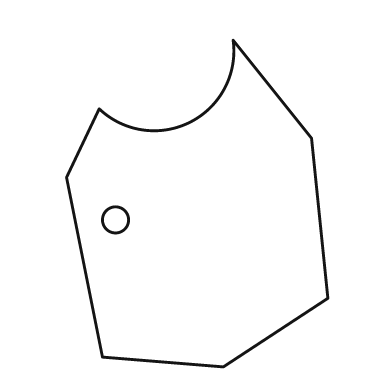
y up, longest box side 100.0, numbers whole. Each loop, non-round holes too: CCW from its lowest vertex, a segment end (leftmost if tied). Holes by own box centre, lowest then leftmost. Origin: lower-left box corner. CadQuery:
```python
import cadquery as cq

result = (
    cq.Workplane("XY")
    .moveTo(48.0, 0.0)
    .lineTo(80.0, 21.0)
    .lineTo(75.0, 70.0)
    .lineTo(51.0, 100.0)
    .threePointArc((38.0, 75.0), (10.0, 79.0))
    .lineTo(0.0, 58.0)
    .lineTo(11.0, 3.0)
    .close()
    .moveTo(15.0, 45.0)
    .circle(4.0)
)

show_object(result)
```